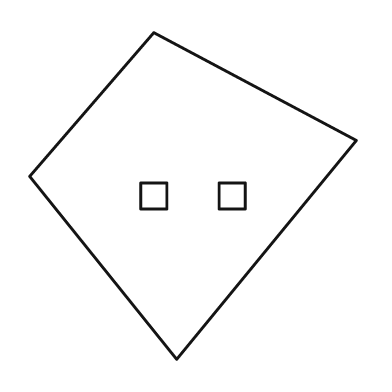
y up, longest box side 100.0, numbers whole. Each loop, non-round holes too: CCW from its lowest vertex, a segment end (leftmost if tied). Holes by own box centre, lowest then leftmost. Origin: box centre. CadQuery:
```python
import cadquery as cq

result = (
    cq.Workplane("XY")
    .moveTo(-5.0, -50.0)
    .lineTo(50.0, 17.0)
    .lineTo(-12.0, 50.0)
    .lineTo(-50.0, 6.0)
    .close()
    .moveTo(-16.0, -4.0)
    .lineTo(-8.0, -4.0)
    .lineTo(-8.0, 4.0)
    .lineTo(-16.0, 4.0)
    .close()
    .moveTo(8.0, -4.0)
    .lineTo(16.0, -4.0)
    .lineTo(16.0, 4.0)
    .lineTo(8.0, 4.0)
    .close()
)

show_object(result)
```